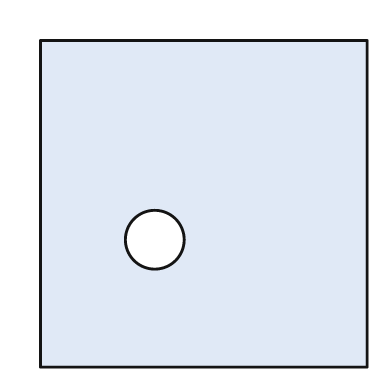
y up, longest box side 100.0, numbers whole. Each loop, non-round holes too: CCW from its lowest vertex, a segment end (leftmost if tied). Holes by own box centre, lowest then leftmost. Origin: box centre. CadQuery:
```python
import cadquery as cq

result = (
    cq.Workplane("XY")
    .moveTo(-50.0, -50.0)
    .lineTo(50.0, -50.0)
    .lineTo(50.0, 50.0)
    .lineTo(-50.0, 50.0)
    .close()
    .moveTo(-15.0, -11.0)
    .circle(9.0)
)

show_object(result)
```